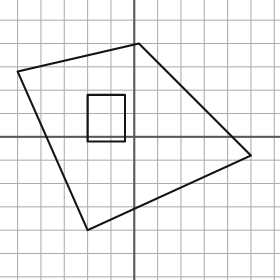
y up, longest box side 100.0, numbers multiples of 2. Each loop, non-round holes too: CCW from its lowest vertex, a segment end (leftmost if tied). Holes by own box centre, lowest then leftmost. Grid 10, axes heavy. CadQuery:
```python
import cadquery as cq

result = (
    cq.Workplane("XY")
    .moveTo(-20.0, -40.0)
    .lineTo(50.0, -8.0)
    .lineTo(2.0, 40.0)
    .lineTo(-50.0, 28.0)
    .close()
    .moveTo(-20.0, -2.0)
    .lineTo(-4.0, -2.0)
    .lineTo(-4.0, 18.0)
    .lineTo(-20.0, 18.0)
    .close()
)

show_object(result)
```